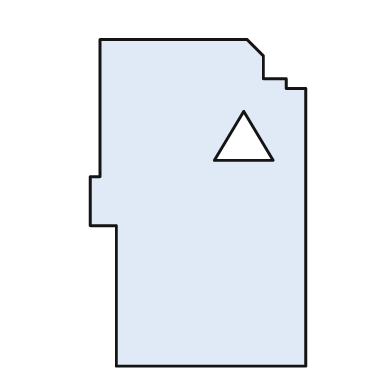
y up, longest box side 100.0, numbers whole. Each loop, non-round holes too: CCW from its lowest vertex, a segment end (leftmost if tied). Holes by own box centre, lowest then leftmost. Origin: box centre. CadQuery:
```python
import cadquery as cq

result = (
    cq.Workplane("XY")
    .moveTo(-25.0, -50.0)
    .lineTo(33.0, -50.0)
    .lineTo(33.0, 35.0)
    .lineTo(27.0, 35.0)
    .lineTo(27.0, 38.0)
    .lineTo(20.0, 38.0)
    .lineTo(20.0, 45.0)
    .lineTo(15.0, 50.0)
    .lineTo(-30.0, 50.0)
    .lineTo(-30.0, 8.0)
    .lineTo(-33.0, 8.0)
    .lineTo(-33.0, -7.0)
    .lineTo(-25.0, -7.0)
    .close()
    .moveTo(5.0, 13.0)
    .lineTo(23.0, 13.0)
    .lineTo(14.0, 28.0)
    .close()
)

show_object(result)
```